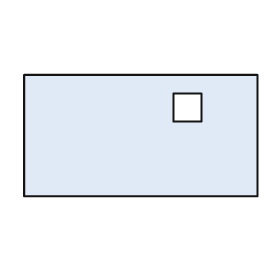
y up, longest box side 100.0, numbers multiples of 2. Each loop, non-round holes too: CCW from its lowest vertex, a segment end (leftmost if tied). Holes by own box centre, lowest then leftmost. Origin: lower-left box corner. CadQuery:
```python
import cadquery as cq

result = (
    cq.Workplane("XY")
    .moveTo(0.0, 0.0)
    .lineTo(100.0, 0.0)
    .lineTo(100.0, 52.0)
    .lineTo(0.0, 52.0)
    .close()
    .moveTo(64.0, 32.0)
    .lineTo(76.0, 32.0)
    .lineTo(76.0, 44.0)
    .lineTo(64.0, 44.0)
    .close()
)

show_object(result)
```